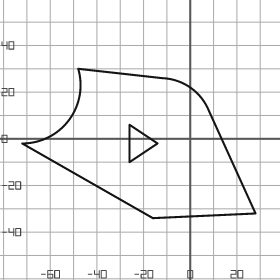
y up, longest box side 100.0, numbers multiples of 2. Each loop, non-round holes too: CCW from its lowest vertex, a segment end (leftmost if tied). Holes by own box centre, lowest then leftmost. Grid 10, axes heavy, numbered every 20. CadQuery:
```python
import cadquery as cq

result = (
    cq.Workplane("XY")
    .moveTo(-16.0, -34.0)
    .lineTo(28.0, -32.0)
    .lineTo(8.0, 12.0)
    .threePointArc((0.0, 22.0), (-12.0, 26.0))
    .lineTo(-48.0, 30.0)
    .threePointArc((-52.0, 8.0), (-72.0, -2.0))
    .close()
    .moveTo(-26.0, -10.0)
    .lineTo(-14.0, -2.0)
    .lineTo(-26.0, 6.0)
    .close()
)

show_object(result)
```